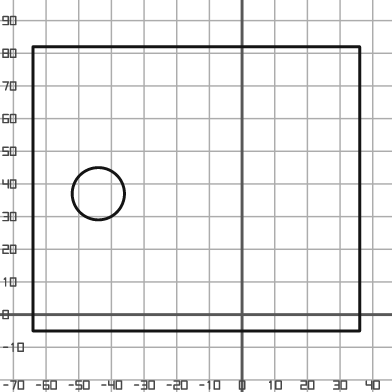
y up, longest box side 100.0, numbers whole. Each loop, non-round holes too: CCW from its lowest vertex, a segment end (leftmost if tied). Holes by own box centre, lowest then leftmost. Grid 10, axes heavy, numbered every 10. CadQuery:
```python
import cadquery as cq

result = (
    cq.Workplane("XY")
    .moveTo(-64.0, -5.0)
    .lineTo(36.0, -5.0)
    .lineTo(36.0, 82.0)
    .lineTo(-64.0, 82.0)
    .close()
    .moveTo(-44.0, 37.0)
    .circle(8.0)
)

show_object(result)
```